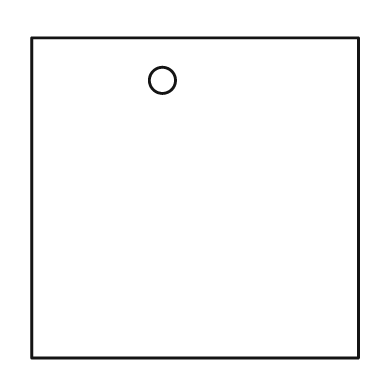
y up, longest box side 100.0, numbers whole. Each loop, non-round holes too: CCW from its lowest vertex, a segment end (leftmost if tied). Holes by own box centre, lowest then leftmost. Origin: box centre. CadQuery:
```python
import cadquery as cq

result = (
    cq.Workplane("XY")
    .moveTo(-50.0, -49.0)
    .lineTo(50.0, -49.0)
    .lineTo(50.0, 49.0)
    .lineTo(-50.0, 49.0)
    .close()
    .moveTo(-10.0, 36.0)
    .circle(4.0)
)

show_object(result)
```